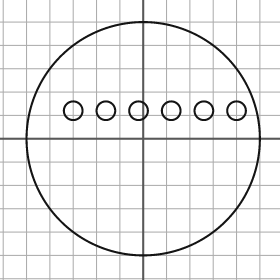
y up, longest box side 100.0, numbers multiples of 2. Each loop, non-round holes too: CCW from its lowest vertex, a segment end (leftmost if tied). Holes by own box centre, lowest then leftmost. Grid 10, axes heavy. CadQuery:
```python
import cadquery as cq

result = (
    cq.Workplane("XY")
    .moveTo(0.0, 0.0)
    .circle(50.0)
    .moveTo(-30.0, 12.0)
    .circle(4.0)
    .moveTo(-16.0, 12.0)
    .circle(4.0)
    .moveTo(-2.0, 12.0)
    .circle(4.0)
    .moveTo(12.0, 12.0)
    .circle(4.0)
    .moveTo(26.0, 12.0)
    .circle(4.0)
    .moveTo(40.0, 12.0)
    .circle(4.0)
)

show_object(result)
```